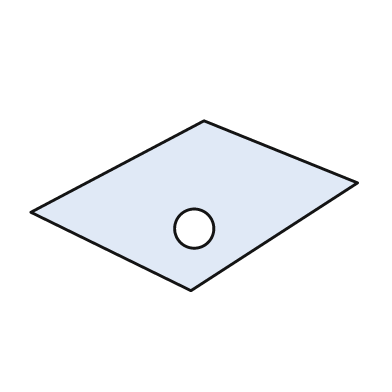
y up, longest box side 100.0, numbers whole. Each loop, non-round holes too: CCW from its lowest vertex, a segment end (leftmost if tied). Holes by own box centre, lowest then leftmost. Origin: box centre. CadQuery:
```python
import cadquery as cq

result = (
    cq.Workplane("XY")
    .moveTo(-1.0, -26.0)
    .lineTo(50.0, 7.0)
    .lineTo(3.0, 26.0)
    .lineTo(-50.0, -2.0)
    .close()
    .moveTo(0.0, -7.0)
    .circle(6.0)
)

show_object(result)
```